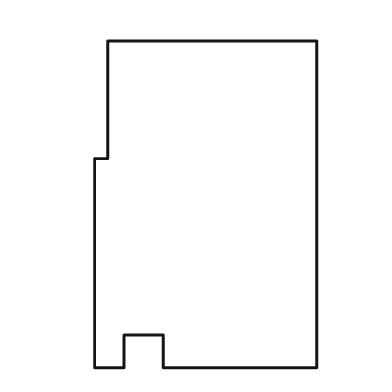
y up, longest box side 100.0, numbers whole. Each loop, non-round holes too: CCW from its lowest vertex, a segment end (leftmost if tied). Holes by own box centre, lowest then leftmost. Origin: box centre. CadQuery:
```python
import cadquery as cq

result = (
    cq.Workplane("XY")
    .moveTo(-34.0, -50.0)
    .lineTo(-25.0, -50.0)
    .lineTo(-25.0, -40.0)
    .lineTo(-13.0, -40.0)
    .lineTo(-13.0, -50.0)
    .lineTo(34.0, -50.0)
    .lineTo(34.0, 50.0)
    .lineTo(-30.0, 50.0)
    .lineTo(-30.0, 14.0)
    .lineTo(-34.0, 14.0)
    .close()
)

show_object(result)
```